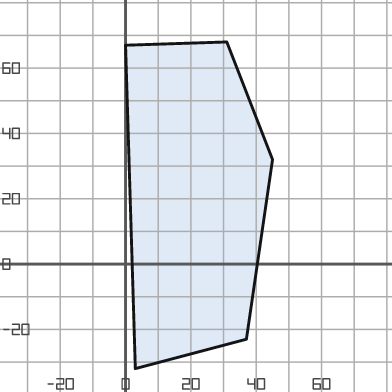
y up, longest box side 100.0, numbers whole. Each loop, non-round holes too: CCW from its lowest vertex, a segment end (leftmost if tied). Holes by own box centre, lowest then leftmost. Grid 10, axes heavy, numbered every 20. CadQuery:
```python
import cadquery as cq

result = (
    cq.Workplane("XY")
    .moveTo(3.0, -32.0)
    .lineTo(37.0, -23.0)
    .lineTo(45.0, 32.0)
    .lineTo(31.0, 68.0)
    .lineTo(0.0, 67.0)
    .close()
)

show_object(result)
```